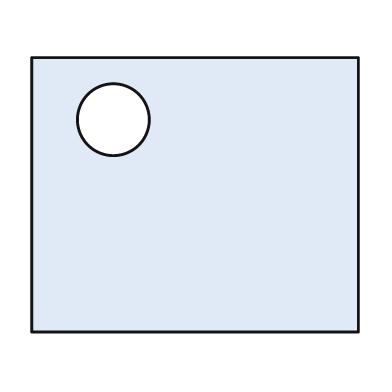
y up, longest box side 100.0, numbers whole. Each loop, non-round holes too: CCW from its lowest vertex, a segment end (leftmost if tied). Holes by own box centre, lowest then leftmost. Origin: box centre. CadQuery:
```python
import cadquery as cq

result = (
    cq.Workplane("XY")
    .moveTo(-50.0, -42.0)
    .lineTo(50.0, -42.0)
    .lineTo(50.0, 42.0)
    .lineTo(-50.0, 42.0)
    .close()
    .moveTo(-25.0, 23.0)
    .circle(11.0)
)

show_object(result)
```